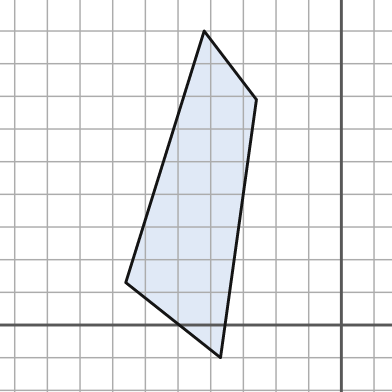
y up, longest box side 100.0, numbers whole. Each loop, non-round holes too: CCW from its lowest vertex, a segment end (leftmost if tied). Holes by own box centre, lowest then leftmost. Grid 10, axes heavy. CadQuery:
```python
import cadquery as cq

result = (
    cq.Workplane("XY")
    .moveTo(-37.0, -10.0)
    .lineTo(-26.0, 69.0)
    .lineTo(-42.0, 90.0)
    .lineTo(-66.0, 13.0)
    .close()
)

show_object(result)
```